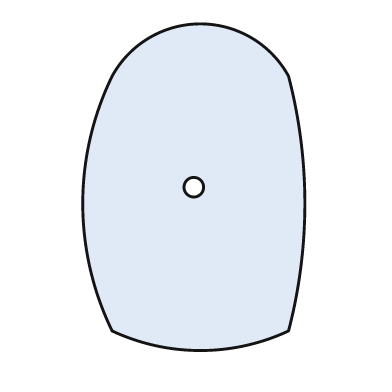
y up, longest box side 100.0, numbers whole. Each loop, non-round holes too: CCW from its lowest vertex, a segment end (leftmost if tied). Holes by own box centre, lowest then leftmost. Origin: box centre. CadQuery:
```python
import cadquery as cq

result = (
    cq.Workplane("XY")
    .moveTo(-25.0, -44.0)
    .threePointArc((2.0, -50.0), (29.0, -44.0))
    .threePointArc((34.0, -5.0), (29.0, 34.0))
    .threePointArc((2.0, 50.0), (-25.0, 34.0))
    .threePointArc((-34.0, -5.0), (-25.0, -44.0))
    .close()
    .moveTo(0.0, 0.0)
    .circle(3.0)
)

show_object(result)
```